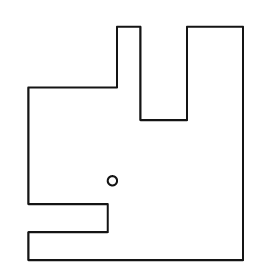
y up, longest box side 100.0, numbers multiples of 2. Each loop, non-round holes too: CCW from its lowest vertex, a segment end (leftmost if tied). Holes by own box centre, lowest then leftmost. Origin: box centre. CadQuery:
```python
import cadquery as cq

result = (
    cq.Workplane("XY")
    .moveTo(-46.0, -50.0)
    .lineTo(46.0, -50.0)
    .lineTo(46.0, 50.0)
    .lineTo(22.0, 50.0)
    .lineTo(22.0, 10.0)
    .lineTo(2.0, 10.0)
    .lineTo(2.0, 50.0)
    .lineTo(-8.0, 50.0)
    .lineTo(-8.0, 24.0)
    .lineTo(-46.0, 24.0)
    .lineTo(-46.0, -26.0)
    .lineTo(-12.0, -26.0)
    .lineTo(-12.0, -38.0)
    .lineTo(-46.0, -38.0)
    .close()
    .moveTo(-10.0, -16.0)
    .circle(2.0)
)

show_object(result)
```